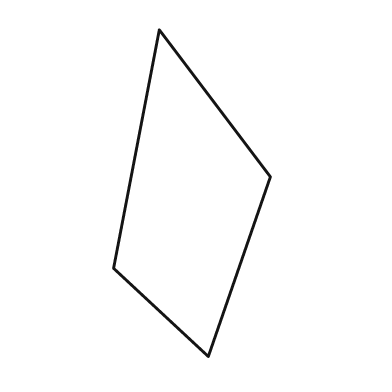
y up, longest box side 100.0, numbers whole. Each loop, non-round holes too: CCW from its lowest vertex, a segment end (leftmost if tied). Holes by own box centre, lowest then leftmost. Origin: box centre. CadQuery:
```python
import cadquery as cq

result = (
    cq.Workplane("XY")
    .moveTo(5.0, -50.0)
    .lineTo(24.0, 5.0)
    .lineTo(-10.0, 50.0)
    .lineTo(-24.0, -23.0)
    .close()
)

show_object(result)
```